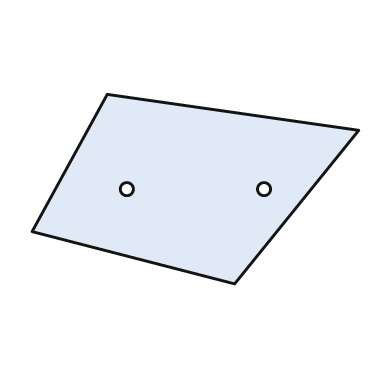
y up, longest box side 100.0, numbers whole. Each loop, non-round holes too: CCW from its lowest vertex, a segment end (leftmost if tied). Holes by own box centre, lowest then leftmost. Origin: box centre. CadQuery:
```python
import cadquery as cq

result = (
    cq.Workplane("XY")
    .moveTo(12.0, -29.0)
    .lineTo(50.0, 18.0)
    .lineTo(-27.0, 29.0)
    .lineTo(-50.0, -13.0)
    .close()
    .moveTo(-21.0, 0.0)
    .circle(2.0)
    .moveTo(21.0, 0.0)
    .circle(2.0)
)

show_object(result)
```